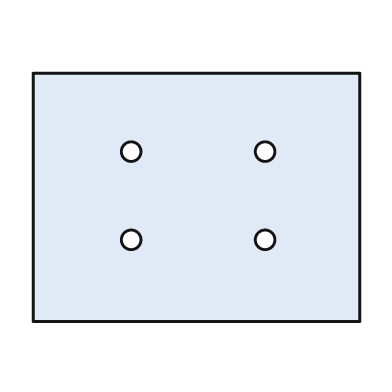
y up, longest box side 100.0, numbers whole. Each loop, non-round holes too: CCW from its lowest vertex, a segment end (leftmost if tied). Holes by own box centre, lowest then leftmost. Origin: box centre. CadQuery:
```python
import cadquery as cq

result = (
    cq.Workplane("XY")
    .moveTo(-50.0, -38.0)
    .lineTo(50.0, -38.0)
    .lineTo(50.0, 38.0)
    .lineTo(-50.0, 38.0)
    .close()
    .moveTo(-20.0, -13.0)
    .circle(3.0)
    .moveTo(21.0, -13.0)
    .circle(3.0)
    .moveTo(-20.0, 14.0)
    .circle(3.0)
    .moveTo(21.0, 14.0)
    .circle(3.0)
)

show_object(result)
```